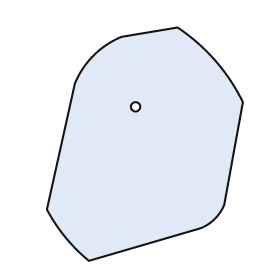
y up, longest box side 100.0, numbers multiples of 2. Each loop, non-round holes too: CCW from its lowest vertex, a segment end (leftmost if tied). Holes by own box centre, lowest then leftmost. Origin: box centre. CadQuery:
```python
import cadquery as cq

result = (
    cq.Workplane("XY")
    .moveTo(-24.0, -50.0)
    .lineTo(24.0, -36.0)
    .threePointArc((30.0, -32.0), (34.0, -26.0))
    .lineTo(42.0, 18.0)
    .threePointArc((30.0, 36.0), (14.0, 50.0))
    .lineTo(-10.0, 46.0)
    .threePointArc((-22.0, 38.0), (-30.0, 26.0))
    .lineTo(-42.0, -28.0)
    .threePointArc((-34.0, -40.0), (-24.0, -50.0))
    .close()
    .moveTo(-4.0, 16.0)
    .circle(2.0)
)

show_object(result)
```